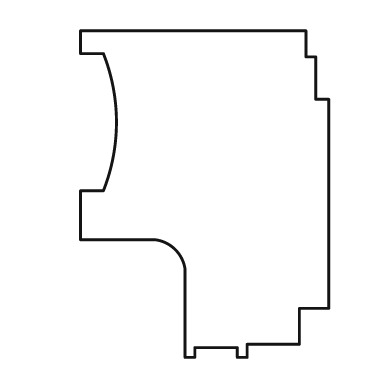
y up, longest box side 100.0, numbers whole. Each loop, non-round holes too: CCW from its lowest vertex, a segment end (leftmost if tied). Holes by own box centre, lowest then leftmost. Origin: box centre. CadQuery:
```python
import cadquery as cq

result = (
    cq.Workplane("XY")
    .moveTo(-6.0, -50.0)
    .lineTo(-3.0, -50.0)
    .lineTo(-3.0, -47.0)
    .lineTo(10.0, -47.0)
    .lineTo(10.0, -50.0)
    .lineTo(13.0, -50.0)
    .lineTo(13.0, -46.0)
    .lineTo(29.0, -46.0)
    .lineTo(29.0, -35.0)
    .lineTo(38.0, -35.0)
    .lineTo(38.0, 29.0)
    .lineTo(34.0, 29.0)
    .lineTo(34.0, 42.0)
    .lineTo(31.0, 42.0)
    .lineTo(31.0, 50.0)
    .lineTo(-38.0, 50.0)
    .lineTo(-38.0, 43.0)
    .lineTo(-31.0, 43.0)
    .threePointArc((-27.0, 22.0), (-31.0, 1.0))
    .lineTo(-38.0, 1.0)
    .lineTo(-38.0, -14.0)
    .lineTo(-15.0, -14.0)
    .threePointArc((-9.0, -17.0), (-6.0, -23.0))
    .close()
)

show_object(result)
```